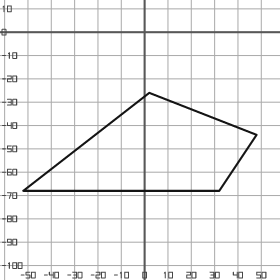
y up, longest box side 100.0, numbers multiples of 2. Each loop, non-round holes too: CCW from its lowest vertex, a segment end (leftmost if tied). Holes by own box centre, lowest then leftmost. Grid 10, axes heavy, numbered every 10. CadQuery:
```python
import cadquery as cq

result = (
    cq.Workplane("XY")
    .moveTo(-52.0, -68.0)
    .lineTo(32.0, -68.0)
    .lineTo(48.0, -44.0)
    .lineTo(2.0, -26.0)
    .close()
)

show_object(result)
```